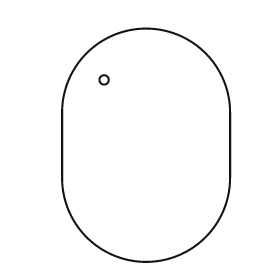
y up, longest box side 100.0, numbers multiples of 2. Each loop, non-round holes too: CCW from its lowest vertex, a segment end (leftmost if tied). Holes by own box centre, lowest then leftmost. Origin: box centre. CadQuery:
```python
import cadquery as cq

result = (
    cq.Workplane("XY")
    .moveTo(-36.0, -14.0)
    .threePointArc((0.0, -50.0), (36.0, -14.0))
    .lineTo(36.0, 14.0)
    .threePointArc((0.0, 50.0), (-36.0, 14.0))
    .close()
    .moveTo(-18.0, 28.0)
    .circle(2.0)
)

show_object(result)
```